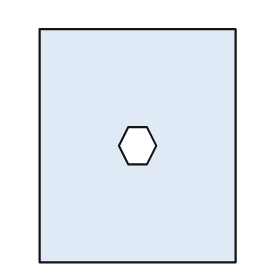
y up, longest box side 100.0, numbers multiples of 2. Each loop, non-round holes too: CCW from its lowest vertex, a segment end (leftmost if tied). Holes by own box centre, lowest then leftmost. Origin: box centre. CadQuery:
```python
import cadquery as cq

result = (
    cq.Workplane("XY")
    .moveTo(-42.0, -50.0)
    .lineTo(42.0, -50.0)
    .lineTo(42.0, 50.0)
    .lineTo(-42.0, 50.0)
    .close()
    .moveTo(-4.0, -8.0)
    .lineTo(4.0, -8.0)
    .lineTo(8.0, 0.0)
    .lineTo(4.0, 8.0)
    .lineTo(-4.0, 8.0)
    .lineTo(-8.0, 0.0)
    .close()
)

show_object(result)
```